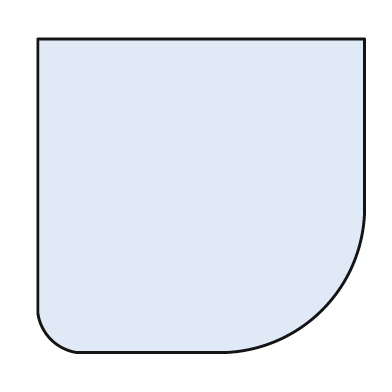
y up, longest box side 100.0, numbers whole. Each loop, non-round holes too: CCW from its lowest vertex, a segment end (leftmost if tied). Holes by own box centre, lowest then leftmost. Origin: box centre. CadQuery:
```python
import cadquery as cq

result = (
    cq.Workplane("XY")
    .moveTo(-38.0, -48.0)
    .lineTo(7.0, -48.0)
    .threePointArc((37.0, -35.0), (50.0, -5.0))
    .lineTo(50.0, 48.0)
    .lineTo(-50.0, 48.0)
    .lineTo(-50.0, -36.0)
    .threePointArc((-46.0, -44.0), (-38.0, -48.0))
    .close()
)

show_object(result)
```